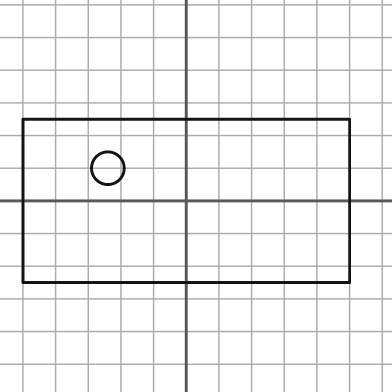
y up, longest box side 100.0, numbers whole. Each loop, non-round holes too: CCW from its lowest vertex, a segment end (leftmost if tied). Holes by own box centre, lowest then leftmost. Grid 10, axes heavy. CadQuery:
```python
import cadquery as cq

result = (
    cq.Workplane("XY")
    .moveTo(-50.0, -25.0)
    .lineTo(50.0, -25.0)
    .lineTo(50.0, 25.0)
    .lineTo(-50.0, 25.0)
    .close()
    .moveTo(-24.0, 10.0)
    .circle(5.0)
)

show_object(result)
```